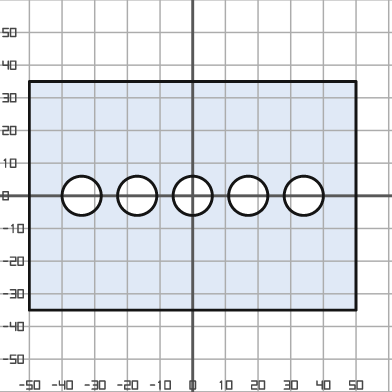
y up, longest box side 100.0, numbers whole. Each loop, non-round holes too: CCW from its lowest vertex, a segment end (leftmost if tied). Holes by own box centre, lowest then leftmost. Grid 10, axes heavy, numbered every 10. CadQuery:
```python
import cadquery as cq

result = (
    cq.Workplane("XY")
    .moveTo(-50.0, -35.0)
    .lineTo(50.0, -35.0)
    .lineTo(50.0, 35.0)
    .lineTo(-50.0, 35.0)
    .close()
    .moveTo(-34.0, 0.0)
    .circle(6.0)
    .moveTo(-17.0, 0.0)
    .circle(6.0)
    .moveTo(0.0, 0.0)
    .circle(6.0)
    .moveTo(17.0, 0.0)
    .circle(6.0)
    .moveTo(34.0, 0.0)
    .circle(6.0)
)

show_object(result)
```